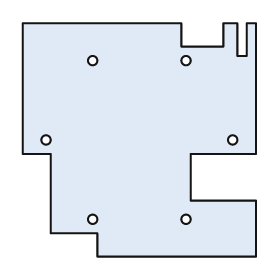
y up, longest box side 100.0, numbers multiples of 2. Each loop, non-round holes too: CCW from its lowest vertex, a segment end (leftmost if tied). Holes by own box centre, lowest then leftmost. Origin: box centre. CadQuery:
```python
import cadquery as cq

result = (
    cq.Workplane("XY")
    .moveTo(-18.0, -50.0)
    .lineTo(50.0, -50.0)
    .lineTo(50.0, -26.0)
    .lineTo(22.0, -26.0)
    .lineTo(22.0, -6.0)
    .lineTo(50.0, -6.0)
    .lineTo(50.0, 50.0)
    .lineTo(46.0, 50.0)
    .lineTo(46.0, 36.0)
    .lineTo(42.0, 36.0)
    .lineTo(42.0, 50.0)
    .lineTo(36.0, 50.0)
    .lineTo(36.0, 40.0)
    .lineTo(18.0, 40.0)
    .lineTo(18.0, 50.0)
    .lineTo(-50.0, 50.0)
    .lineTo(-50.0, -6.0)
    .lineTo(-38.0, -6.0)
    .lineTo(-38.0, -40.0)
    .lineTo(-18.0, -40.0)
    .close()
    .moveTo(-20.0, -34.0)
    .circle(2.0)
    .moveTo(20.0, -34.0)
    .circle(2.0)
    .moveTo(-40.0, 0.0)
    .circle(2.0)
    .moveTo(40.0, 0.0)
    .circle(2.0)
    .moveTo(-20.0, 34.0)
    .circle(2.0)
    .moveTo(20.0, 34.0)
    .circle(2.0)
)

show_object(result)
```